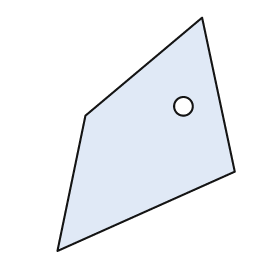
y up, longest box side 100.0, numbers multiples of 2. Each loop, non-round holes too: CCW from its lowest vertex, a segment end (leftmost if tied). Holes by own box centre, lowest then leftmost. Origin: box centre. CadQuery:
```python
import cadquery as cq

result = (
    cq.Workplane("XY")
    .moveTo(-38.0, -50.0)
    .lineTo(38.0, -16.0)
    .lineTo(24.0, 50.0)
    .lineTo(-26.0, 8.0)
    .close()
    .moveTo(16.0, 12.0)
    .circle(4.0)
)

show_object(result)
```